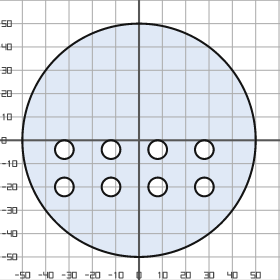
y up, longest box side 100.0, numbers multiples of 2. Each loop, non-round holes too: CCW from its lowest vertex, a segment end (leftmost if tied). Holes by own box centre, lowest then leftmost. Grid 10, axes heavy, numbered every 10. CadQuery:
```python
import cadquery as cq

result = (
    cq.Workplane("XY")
    .moveTo(0.0, 0.0)
    .circle(50.0)
    .moveTo(-32.0, -20.0)
    .circle(4.0)
    .moveTo(-12.0, -20.0)
    .circle(4.0)
    .moveTo(8.0, -20.0)
    .circle(4.0)
    .moveTo(28.0, -20.0)
    .circle(4.0)
    .moveTo(-32.0, -4.0)
    .circle(4.0)
    .moveTo(-12.0, -4.0)
    .circle(4.0)
    .moveTo(8.0, -4.0)
    .circle(4.0)
    .moveTo(28.0, -4.0)
    .circle(4.0)
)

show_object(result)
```